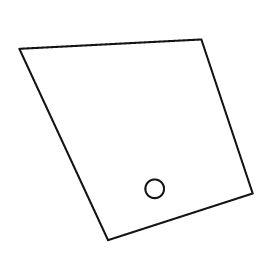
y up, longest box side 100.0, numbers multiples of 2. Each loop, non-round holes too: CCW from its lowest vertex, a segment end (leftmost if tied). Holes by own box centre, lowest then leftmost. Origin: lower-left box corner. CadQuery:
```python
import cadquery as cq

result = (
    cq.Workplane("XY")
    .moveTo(38.0, 0.0)
    .lineTo(100.0, 20.0)
    .lineTo(78.0, 86.0)
    .lineTo(0.0, 82.0)
    .close()
    .moveTo(58.0, 22.0)
    .circle(4.0)
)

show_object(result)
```